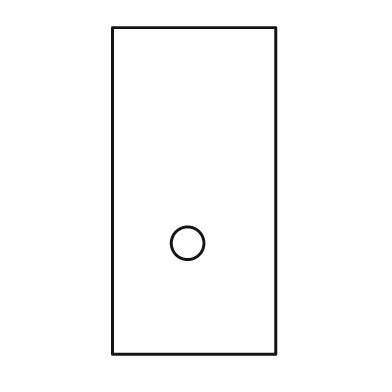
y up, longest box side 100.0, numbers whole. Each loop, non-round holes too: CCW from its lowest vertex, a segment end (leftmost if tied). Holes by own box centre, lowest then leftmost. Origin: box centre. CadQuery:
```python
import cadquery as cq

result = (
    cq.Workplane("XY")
    .moveTo(-25.0, -50.0)
    .lineTo(25.0, -50.0)
    .lineTo(25.0, 50.0)
    .lineTo(-25.0, 50.0)
    .close()
    .moveTo(-2.0, -16.0)
    .circle(5.0)
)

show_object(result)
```